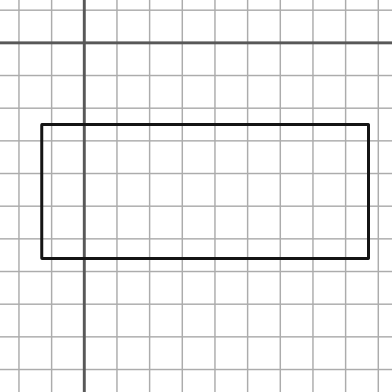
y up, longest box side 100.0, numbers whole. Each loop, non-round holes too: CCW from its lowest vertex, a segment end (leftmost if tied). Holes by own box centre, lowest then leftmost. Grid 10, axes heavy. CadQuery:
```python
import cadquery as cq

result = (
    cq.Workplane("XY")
    .moveTo(-13.0, -66.0)
    .lineTo(87.0, -66.0)
    .lineTo(87.0, -25.0)
    .lineTo(-13.0, -25.0)
    .close()
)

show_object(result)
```